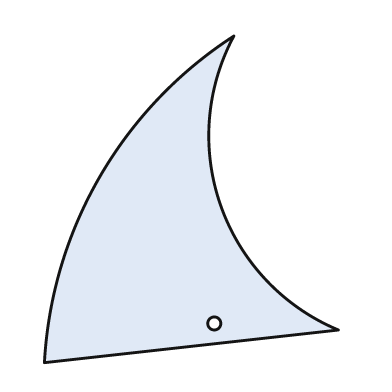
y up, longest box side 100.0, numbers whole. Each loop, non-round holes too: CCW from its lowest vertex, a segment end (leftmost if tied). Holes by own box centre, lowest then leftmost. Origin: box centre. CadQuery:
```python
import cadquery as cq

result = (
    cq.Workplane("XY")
    .moveTo(-45.0, -50.0)
    .lineTo(45.0, -40.0)
    .threePointArc((9.0, -2.0), (13.0, 50.0))
    .threePointArc((-28.0, 7.0), (-45.0, -50.0))
    .close()
    .moveTo(7.0, -38.0)
    .circle(2.0)
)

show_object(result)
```